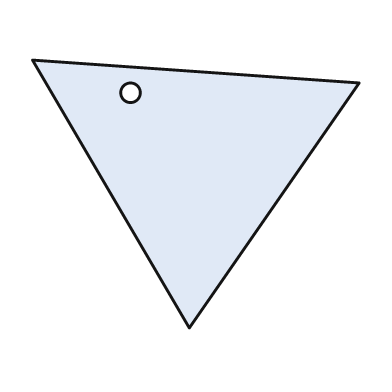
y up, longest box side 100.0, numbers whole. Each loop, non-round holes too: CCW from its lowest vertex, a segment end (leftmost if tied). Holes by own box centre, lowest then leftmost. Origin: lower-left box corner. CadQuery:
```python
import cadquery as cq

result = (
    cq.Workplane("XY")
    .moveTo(48.0, 0.0)
    .lineTo(100.0, 75.0)
    .lineTo(0.0, 82.0)
    .close()
    .moveTo(30.0, 72.0)
    .circle(3.0)
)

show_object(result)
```